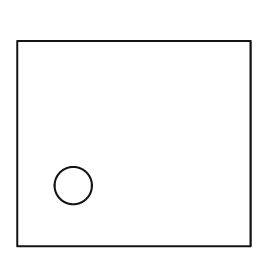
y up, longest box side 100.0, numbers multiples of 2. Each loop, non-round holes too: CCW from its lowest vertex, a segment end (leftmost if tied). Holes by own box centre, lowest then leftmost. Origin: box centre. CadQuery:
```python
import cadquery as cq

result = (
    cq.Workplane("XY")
    .moveTo(-50.0, -44.0)
    .lineTo(50.0, -44.0)
    .lineTo(50.0, 44.0)
    .lineTo(-50.0, 44.0)
    .close()
    .moveTo(-26.0, -18.0)
    .circle(8.0)
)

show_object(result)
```